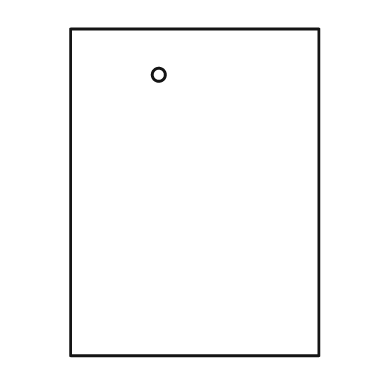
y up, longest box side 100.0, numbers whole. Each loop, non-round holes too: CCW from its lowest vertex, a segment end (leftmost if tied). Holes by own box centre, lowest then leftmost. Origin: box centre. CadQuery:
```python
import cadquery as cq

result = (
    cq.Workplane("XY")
    .moveTo(-38.0, -50.0)
    .lineTo(38.0, -50.0)
    .lineTo(38.0, 50.0)
    .lineTo(-38.0, 50.0)
    .close()
    .moveTo(-11.0, 36.0)
    .circle(2.0)
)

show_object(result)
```